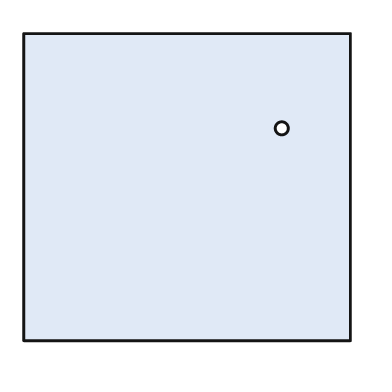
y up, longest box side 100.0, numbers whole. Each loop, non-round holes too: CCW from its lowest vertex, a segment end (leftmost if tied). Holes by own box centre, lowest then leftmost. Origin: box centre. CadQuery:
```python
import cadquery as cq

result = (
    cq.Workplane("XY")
    .moveTo(-50.0, -47.0)
    .lineTo(50.0, -47.0)
    .lineTo(50.0, 47.0)
    .lineTo(-50.0, 47.0)
    .close()
    .moveTo(29.0, 18.0)
    .circle(2.0)
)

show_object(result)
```